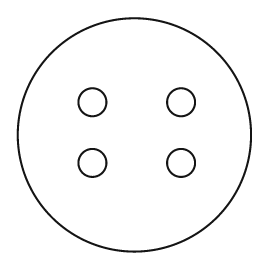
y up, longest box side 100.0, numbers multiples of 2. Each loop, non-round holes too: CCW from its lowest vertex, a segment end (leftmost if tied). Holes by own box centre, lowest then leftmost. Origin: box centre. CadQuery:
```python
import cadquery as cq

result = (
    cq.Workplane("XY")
    .moveTo(0.0, 0.0)
    .circle(50.0)
    .moveTo(-18.0, -12.0)
    .circle(6.0)
    .moveTo(20.0, -12.0)
    .circle(6.0)
    .moveTo(-18.0, 14.0)
    .circle(6.0)
    .moveTo(20.0, 14.0)
    .circle(6.0)
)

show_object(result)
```